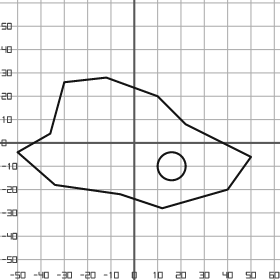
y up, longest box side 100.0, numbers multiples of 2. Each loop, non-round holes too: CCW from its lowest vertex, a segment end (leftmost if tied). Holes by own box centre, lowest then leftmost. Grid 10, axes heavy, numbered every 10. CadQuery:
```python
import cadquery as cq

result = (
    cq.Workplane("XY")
    .moveTo(12.0, -28.0)
    .lineTo(40.0, -20.0)
    .lineTo(50.0, -6.0)
    .lineTo(22.0, 8.0)
    .lineTo(10.0, 20.0)
    .lineTo(-12.0, 28.0)
    .lineTo(-30.0, 26.0)
    .lineTo(-36.0, 4.0)
    .lineTo(-50.0, -4.0)
    .lineTo(-34.0, -18.0)
    .lineTo(-6.0, -22.0)
    .close()
    .moveTo(16.0, -10.0)
    .circle(6.0)
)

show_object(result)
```